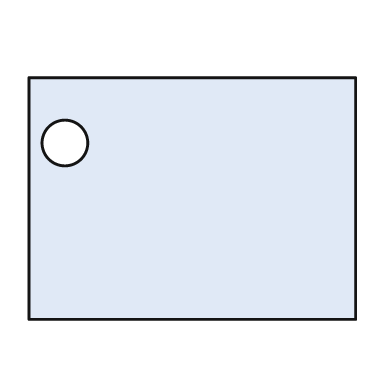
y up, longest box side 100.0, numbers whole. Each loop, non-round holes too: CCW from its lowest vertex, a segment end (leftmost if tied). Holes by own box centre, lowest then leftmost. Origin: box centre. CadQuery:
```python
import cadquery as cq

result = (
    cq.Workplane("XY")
    .moveTo(-50.0, -37.0)
    .lineTo(50.0, -37.0)
    .lineTo(50.0, 37.0)
    .lineTo(-50.0, 37.0)
    .close()
    .moveTo(-39.0, 17.0)
    .circle(7.0)
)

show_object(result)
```